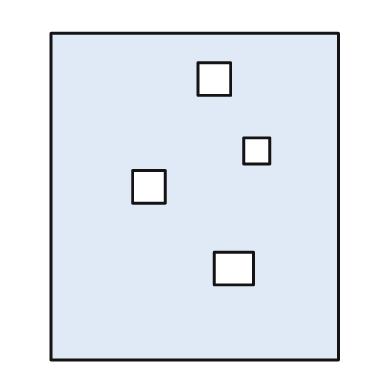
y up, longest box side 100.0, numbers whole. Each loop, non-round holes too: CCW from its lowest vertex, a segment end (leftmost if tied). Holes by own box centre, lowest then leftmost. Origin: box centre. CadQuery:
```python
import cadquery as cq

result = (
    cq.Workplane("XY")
    .moveTo(-44.0, -50.0)
    .lineTo(44.0, -50.0)
    .lineTo(44.0, 50.0)
    .lineTo(-44.0, 50.0)
    .close()
    .moveTo(6.0, -27.0)
    .lineTo(18.0, -27.0)
    .lineTo(18.0, -17.0)
    .lineTo(6.0, -17.0)
    .close()
    .moveTo(-19.0, -2.0)
    .lineTo(-9.0, -2.0)
    .lineTo(-9.0, 8.0)
    .lineTo(-19.0, 8.0)
    .close()
    .moveTo(15.0, 10.0)
    .lineTo(23.0, 10.0)
    .lineTo(23.0, 18.0)
    .lineTo(15.0, 18.0)
    .close()
    .moveTo(1.0, 31.0)
    .lineTo(11.0, 31.0)
    .lineTo(11.0, 41.0)
    .lineTo(1.0, 41.0)
    .close()
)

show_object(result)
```